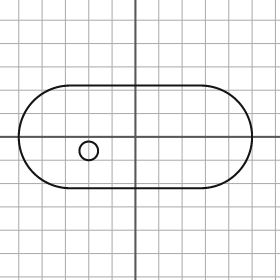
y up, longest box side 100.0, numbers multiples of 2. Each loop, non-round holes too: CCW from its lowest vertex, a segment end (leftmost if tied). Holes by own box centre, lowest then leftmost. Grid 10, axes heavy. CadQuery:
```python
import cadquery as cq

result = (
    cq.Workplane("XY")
    .moveTo(-28.0, -22.0)
    .lineTo(28.0, -22.0)
    .threePointArc((50.0, 0.0), (28.0, 22.0))
    .lineTo(-28.0, 22.0)
    .threePointArc((-50.0, 0.0), (-28.0, -22.0))
    .close()
    .moveTo(-20.0, -6.0)
    .circle(4.0)
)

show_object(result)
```